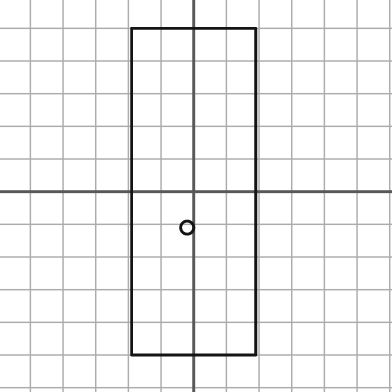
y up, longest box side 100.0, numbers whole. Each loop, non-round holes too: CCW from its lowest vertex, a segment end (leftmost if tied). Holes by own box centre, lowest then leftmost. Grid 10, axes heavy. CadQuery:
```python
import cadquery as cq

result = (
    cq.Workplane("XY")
    .moveTo(-19.0, -50.0)
    .lineTo(19.0, -50.0)
    .lineTo(19.0, 50.0)
    .lineTo(-19.0, 50.0)
    .close()
    .moveTo(-2.0, -11.0)
    .circle(2.0)
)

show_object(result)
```